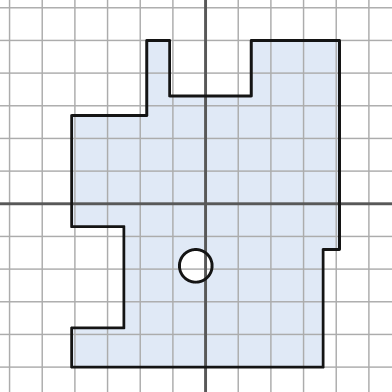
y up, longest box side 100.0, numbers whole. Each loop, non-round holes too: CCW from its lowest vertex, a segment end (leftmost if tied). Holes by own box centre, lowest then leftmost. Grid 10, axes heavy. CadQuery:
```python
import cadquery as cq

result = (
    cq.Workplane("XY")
    .moveTo(-41.0, -50.0)
    .lineTo(36.0, -50.0)
    .lineTo(36.0, -14.0)
    .lineTo(41.0, -14.0)
    .lineTo(41.0, 50.0)
    .lineTo(14.0, 50.0)
    .lineTo(14.0, 33.0)
    .lineTo(-11.0, 33.0)
    .lineTo(-11.0, 50.0)
    .lineTo(-18.0, 50.0)
    .lineTo(-18.0, 27.0)
    .lineTo(-41.0, 27.0)
    .lineTo(-41.0, -7.0)
    .lineTo(-25.0, -7.0)
    .lineTo(-25.0, -38.0)
    .lineTo(-41.0, -38.0)
    .close()
    .moveTo(-3.0, -19.0)
    .circle(5.0)
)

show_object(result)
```